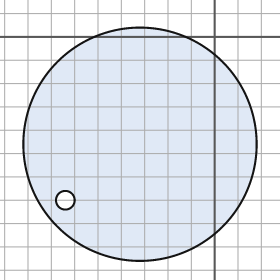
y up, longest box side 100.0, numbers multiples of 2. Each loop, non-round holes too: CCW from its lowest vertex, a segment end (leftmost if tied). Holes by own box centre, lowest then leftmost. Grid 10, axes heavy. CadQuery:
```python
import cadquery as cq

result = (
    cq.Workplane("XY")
    .moveTo(-32.0, -46.0)
    .circle(50.0)
    .moveTo(-64.0, -70.0)
    .circle(4.0)
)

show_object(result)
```